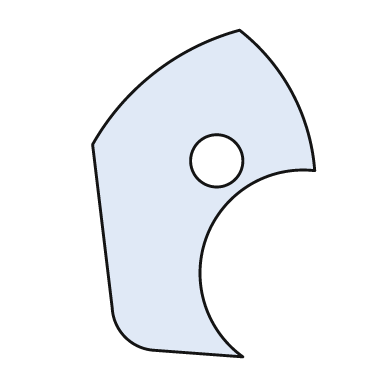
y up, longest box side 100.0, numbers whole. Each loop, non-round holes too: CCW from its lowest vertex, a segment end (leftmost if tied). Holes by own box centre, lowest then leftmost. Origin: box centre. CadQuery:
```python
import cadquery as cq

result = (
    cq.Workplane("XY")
    .moveTo(12.0, -50.0)
    .threePointArc((1.0, -13.0), (34.0, 7.0))
    .threePointArc((27.0, 31.0), (11.0, 50.0))
    .threePointArc((-15.0, 37.0), (-34.0, 15.0))
    .lineTo(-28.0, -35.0)
    .threePointArc((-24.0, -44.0), (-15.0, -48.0))
    .close()
    .moveTo(4.0, 10.0)
    .circle(8.0)
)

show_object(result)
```